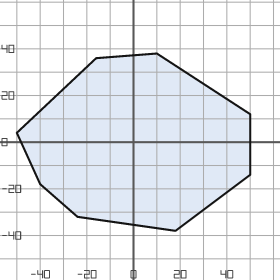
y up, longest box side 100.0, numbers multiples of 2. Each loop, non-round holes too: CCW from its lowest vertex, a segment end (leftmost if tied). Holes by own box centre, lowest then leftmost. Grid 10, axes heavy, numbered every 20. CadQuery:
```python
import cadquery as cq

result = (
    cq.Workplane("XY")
    .moveTo(18.0, -38.0)
    .lineTo(50.0, -14.0)
    .lineTo(50.0, 12.0)
    .lineTo(10.0, 38.0)
    .lineTo(-16.0, 36.0)
    .lineTo(-50.0, 4.0)
    .lineTo(-40.0, -18.0)
    .lineTo(-24.0, -32.0)
    .close()
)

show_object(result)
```